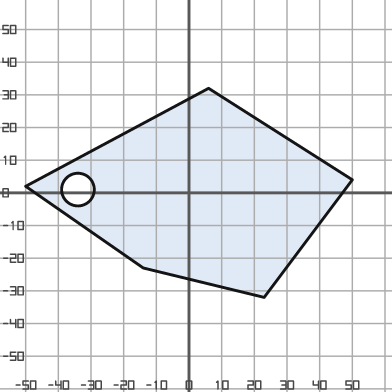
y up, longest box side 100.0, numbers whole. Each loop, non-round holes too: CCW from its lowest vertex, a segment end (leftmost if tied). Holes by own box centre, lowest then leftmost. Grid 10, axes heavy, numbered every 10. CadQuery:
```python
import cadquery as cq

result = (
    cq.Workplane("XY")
    .moveTo(23.0, -32.0)
    .lineTo(50.0, 4.0)
    .lineTo(6.0, 32.0)
    .lineTo(-50.0, 2.0)
    .lineTo(-14.0, -23.0)
    .close()
    .moveTo(-34.0, 1.0)
    .circle(5.0)
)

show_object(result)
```